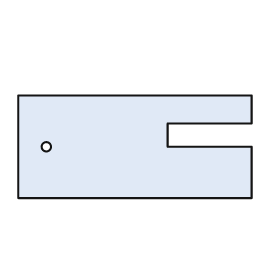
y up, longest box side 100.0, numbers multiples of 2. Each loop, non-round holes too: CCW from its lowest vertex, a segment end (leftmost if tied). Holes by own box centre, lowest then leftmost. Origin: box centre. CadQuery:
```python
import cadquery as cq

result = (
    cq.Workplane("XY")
    .moveTo(-50.0, -22.0)
    .lineTo(50.0, -22.0)
    .lineTo(50.0, 0.0)
    .lineTo(14.0, 0.0)
    .lineTo(14.0, 10.0)
    .lineTo(50.0, 10.0)
    .lineTo(50.0, 22.0)
    .lineTo(-50.0, 22.0)
    .close()
    .moveTo(-38.0, 0.0)
    .circle(2.0)
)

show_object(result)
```